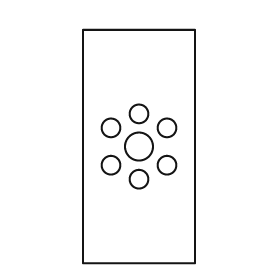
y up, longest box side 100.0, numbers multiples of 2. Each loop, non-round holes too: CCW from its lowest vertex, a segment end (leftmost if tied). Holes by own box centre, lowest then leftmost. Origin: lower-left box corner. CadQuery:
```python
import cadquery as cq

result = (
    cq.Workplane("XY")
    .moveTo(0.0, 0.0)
    .lineTo(48.0, 0.0)
    .lineTo(48.0, 100.0)
    .lineTo(0.0, 100.0)
    .close()
    .moveTo(24.0, 36.0)
    .circle(4.0)
    .moveTo(12.0, 42.0)
    .circle(4.0)
    .moveTo(36.0, 42.0)
    .circle(4.0)
    .moveTo(24.0, 50.0)
    .circle(6.0)
    .moveTo(12.0, 58.0)
    .circle(4.0)
    .moveTo(36.0, 58.0)
    .circle(4.0)
    .moveTo(24.0, 64.0)
    .circle(4.0)
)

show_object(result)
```